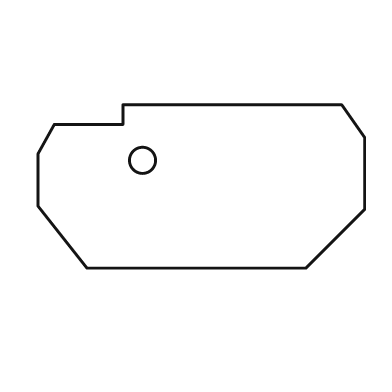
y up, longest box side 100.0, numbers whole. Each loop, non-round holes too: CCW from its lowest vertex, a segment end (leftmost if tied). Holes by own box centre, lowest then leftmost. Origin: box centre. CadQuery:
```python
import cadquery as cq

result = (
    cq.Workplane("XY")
    .moveTo(-35.0, -25.0)
    .lineTo(32.0, -25.0)
    .lineTo(50.0, -7.0)
    .lineTo(50.0, 15.0)
    .lineTo(43.0, 25.0)
    .lineTo(-24.0, 25.0)
    .lineTo(-24.0, 19.0)
    .lineTo(-45.0, 19.0)
    .lineTo(-50.0, 10.0)
    .lineTo(-50.0, -6.0)
    .close()
    .moveTo(-18.0, 8.0)
    .circle(4.0)
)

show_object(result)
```